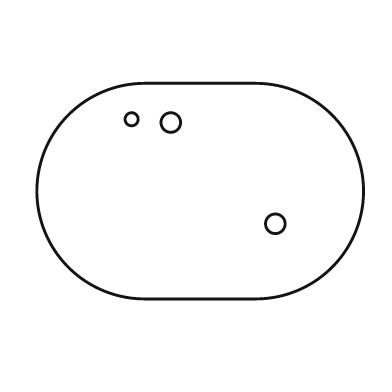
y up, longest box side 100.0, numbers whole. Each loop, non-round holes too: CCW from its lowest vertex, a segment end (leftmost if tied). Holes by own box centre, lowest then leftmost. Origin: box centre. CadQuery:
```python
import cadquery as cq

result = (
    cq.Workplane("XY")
    .moveTo(-17.0, -33.0)
    .lineTo(17.0, -33.0)
    .threePointArc((50.0, 0.0), (17.0, 33.0))
    .lineTo(-17.0, 33.0)
    .threePointArc((-50.0, 0.0), (-17.0, -33.0))
    .close()
    .moveTo(23.0, -10.0)
    .circle(3.0)
    .moveTo(-9.0, 21.0)
    .circle(3.0)
    .moveTo(-21.0, 22.0)
    .circle(2.0)
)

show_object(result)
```